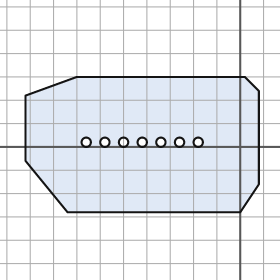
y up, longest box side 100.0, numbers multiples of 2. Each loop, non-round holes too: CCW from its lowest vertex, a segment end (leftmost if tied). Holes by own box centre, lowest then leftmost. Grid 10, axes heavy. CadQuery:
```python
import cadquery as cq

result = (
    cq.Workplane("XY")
    .moveTo(-74.0, -28.0)
    .lineTo(0.0, -28.0)
    .lineTo(8.0, -16.0)
    .lineTo(8.0, 24.0)
    .lineTo(2.0, 30.0)
    .lineTo(-70.0, 30.0)
    .lineTo(-92.0, 22.0)
    .lineTo(-92.0, -6.0)
    .close()
    .moveTo(-66.0, 2.0)
    .circle(2.0)
    .moveTo(-58.0, 2.0)
    .circle(2.0)
    .moveTo(-50.0, 2.0)
    .circle(2.0)
    .moveTo(-42.0, 2.0)
    .circle(2.0)
    .moveTo(-34.0, 2.0)
    .circle(2.0)
    .moveTo(-26.0, 2.0)
    .circle(2.0)
    .moveTo(-18.0, 2.0)
    .circle(2.0)
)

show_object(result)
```